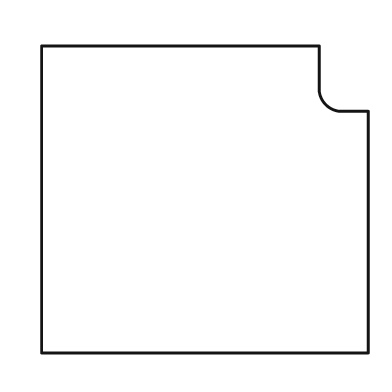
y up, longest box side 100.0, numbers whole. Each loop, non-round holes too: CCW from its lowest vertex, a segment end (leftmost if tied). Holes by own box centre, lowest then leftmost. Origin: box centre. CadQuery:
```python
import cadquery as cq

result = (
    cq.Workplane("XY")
    .moveTo(-50.0, -47.0)
    .lineTo(50.0, -47.0)
    .lineTo(50.0, 27.0)
    .lineTo(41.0, 27.0)
    .threePointArc((37.0, 29.0), (35.0, 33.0))
    .lineTo(35.0, 47.0)
    .lineTo(-50.0, 47.0)
    .close()
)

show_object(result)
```